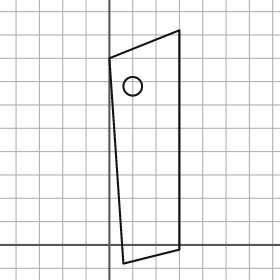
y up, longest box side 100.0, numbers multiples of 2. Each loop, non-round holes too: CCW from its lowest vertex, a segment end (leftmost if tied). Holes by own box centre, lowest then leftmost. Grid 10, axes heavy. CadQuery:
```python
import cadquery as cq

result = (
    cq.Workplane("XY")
    .moveTo(6.0, -8.0)
    .lineTo(30.0, -2.0)
    .lineTo(30.0, 92.0)
    .lineTo(0.0, 80.0)
    .close()
    .moveTo(10.0, 68.0)
    .circle(4.0)
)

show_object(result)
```